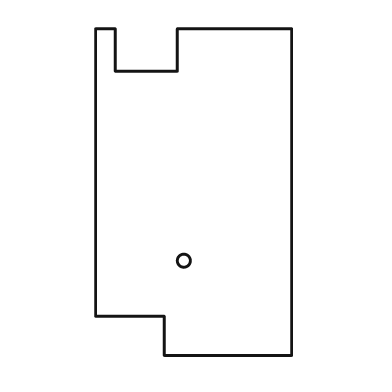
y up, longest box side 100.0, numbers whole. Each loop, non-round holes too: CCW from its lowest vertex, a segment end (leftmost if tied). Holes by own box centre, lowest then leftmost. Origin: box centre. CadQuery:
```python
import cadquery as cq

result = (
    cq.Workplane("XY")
    .moveTo(-9.0, -50.0)
    .lineTo(30.0, -50.0)
    .lineTo(30.0, 50.0)
    .lineTo(-5.0, 50.0)
    .lineTo(-5.0, 37.0)
    .lineTo(-24.0, 37.0)
    .lineTo(-24.0, 50.0)
    .lineTo(-30.0, 50.0)
    .lineTo(-30.0, -38.0)
    .lineTo(-9.0, -38.0)
    .close()
    .moveTo(-3.0, -21.0)
    .circle(2.0)
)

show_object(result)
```